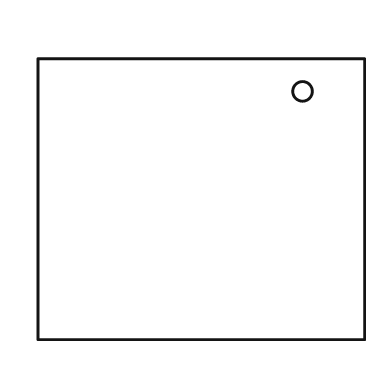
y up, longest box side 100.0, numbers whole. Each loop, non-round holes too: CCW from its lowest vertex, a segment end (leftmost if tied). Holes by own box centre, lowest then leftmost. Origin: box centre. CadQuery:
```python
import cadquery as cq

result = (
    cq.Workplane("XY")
    .moveTo(-50.0, -43.0)
    .lineTo(50.0, -43.0)
    .lineTo(50.0, 43.0)
    .lineTo(-50.0, 43.0)
    .close()
    .moveTo(31.0, 33.0)
    .circle(3.0)
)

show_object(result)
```